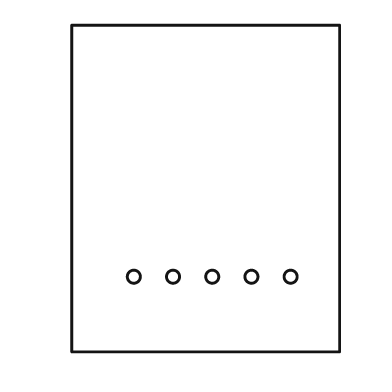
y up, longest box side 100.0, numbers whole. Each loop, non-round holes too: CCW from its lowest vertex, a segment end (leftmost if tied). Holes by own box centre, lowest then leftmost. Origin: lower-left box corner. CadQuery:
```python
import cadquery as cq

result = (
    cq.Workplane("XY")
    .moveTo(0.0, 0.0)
    .lineTo(82.0, 0.0)
    .lineTo(82.0, 100.0)
    .lineTo(0.0, 100.0)
    .close()
    .moveTo(19.0, 23.0)
    .circle(2.0)
    .moveTo(31.0, 23.0)
    .circle(2.0)
    .moveTo(43.0, 23.0)
    .circle(2.0)
    .moveTo(55.0, 23.0)
    .circle(2.0)
    .moveTo(67.0, 23.0)
    .circle(2.0)
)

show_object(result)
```